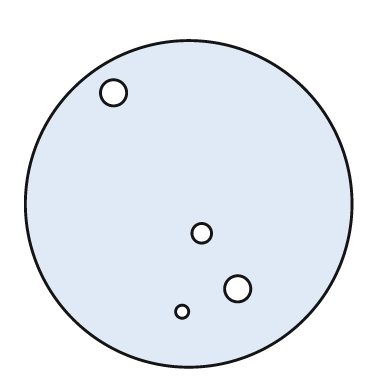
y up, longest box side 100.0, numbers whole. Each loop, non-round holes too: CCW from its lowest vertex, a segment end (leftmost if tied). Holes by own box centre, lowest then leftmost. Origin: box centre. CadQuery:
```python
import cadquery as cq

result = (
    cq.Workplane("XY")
    .moveTo(0.0, 0.0)
    .circle(50.0)
    .moveTo(-2.0, -33.0)
    .circle(2.0)
    .moveTo(15.0, -26.0)
    .circle(4.0)
    .moveTo(4.0, -9.0)
    .circle(3.0)
    .moveTo(-23.0, 34.0)
    .circle(4.0)
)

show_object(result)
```